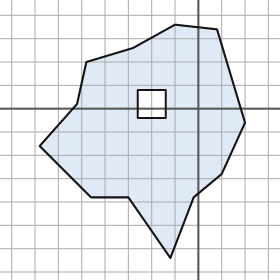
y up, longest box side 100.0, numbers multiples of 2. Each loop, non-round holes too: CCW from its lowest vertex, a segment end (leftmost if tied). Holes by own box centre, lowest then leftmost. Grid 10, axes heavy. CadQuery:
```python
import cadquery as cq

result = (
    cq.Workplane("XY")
    .moveTo(-12.0, -64.0)
    .lineTo(-2.0, -38.0)
    .lineTo(10.0, -28.0)
    .lineTo(20.0, -6.0)
    .lineTo(8.0, 34.0)
    .lineTo(-10.0, 36.0)
    .lineTo(-28.0, 26.0)
    .lineTo(-48.0, 20.0)
    .lineTo(-52.0, 2.0)
    .lineTo(-68.0, -16.0)
    .lineTo(-46.0, -38.0)
    .lineTo(-30.0, -38.0)
    .close()
    .moveTo(-26.0, -4.0)
    .lineTo(-14.0, -4.0)
    .lineTo(-14.0, 8.0)
    .lineTo(-26.0, 8.0)
    .close()
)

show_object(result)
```